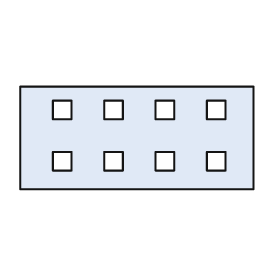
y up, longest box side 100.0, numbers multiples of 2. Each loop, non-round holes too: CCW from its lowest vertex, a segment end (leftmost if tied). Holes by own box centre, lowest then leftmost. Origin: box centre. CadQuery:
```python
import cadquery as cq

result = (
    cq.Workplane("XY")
    .moveTo(-50.0, -22.0)
    .lineTo(50.0, -22.0)
    .lineTo(50.0, 22.0)
    .lineTo(-50.0, 22.0)
    .close()
    .moveTo(-36.0, -14.0)
    .lineTo(-28.0, -14.0)
    .lineTo(-28.0, -6.0)
    .lineTo(-36.0, -6.0)
    .close()
    .moveTo(-14.0, -14.0)
    .lineTo(-6.0, -14.0)
    .lineTo(-6.0, -6.0)
    .lineTo(-14.0, -6.0)
    .close()
    .moveTo(8.0, -14.0)
    .lineTo(16.0, -14.0)
    .lineTo(16.0, -6.0)
    .lineTo(8.0, -6.0)
    .close()
    .moveTo(30.0, -14.0)
    .lineTo(38.0, -14.0)
    .lineTo(38.0, -6.0)
    .lineTo(30.0, -6.0)
    .close()
    .moveTo(-36.0, 8.0)
    .lineTo(-28.0, 8.0)
    .lineTo(-28.0, 16.0)
    .lineTo(-36.0, 16.0)
    .close()
    .moveTo(-14.0, 8.0)
    .lineTo(-6.0, 8.0)
    .lineTo(-6.0, 16.0)
    .lineTo(-14.0, 16.0)
    .close()
    .moveTo(8.0, 8.0)
    .lineTo(16.0, 8.0)
    .lineTo(16.0, 16.0)
    .lineTo(8.0, 16.0)
    .close()
    .moveTo(30.0, 8.0)
    .lineTo(38.0, 8.0)
    .lineTo(38.0, 16.0)
    .lineTo(30.0, 16.0)
    .close()
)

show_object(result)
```